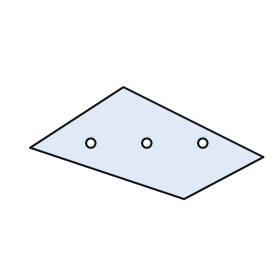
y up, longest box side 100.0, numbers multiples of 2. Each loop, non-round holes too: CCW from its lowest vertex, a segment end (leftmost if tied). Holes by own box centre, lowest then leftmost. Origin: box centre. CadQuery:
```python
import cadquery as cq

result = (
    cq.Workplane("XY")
    .moveTo(16.0, -24.0)
    .lineTo(50.0, -6.0)
    .lineTo(-10.0, 24.0)
    .lineTo(-50.0, -2.0)
    .close()
    .moveTo(-24.0, 0.0)
    .circle(2.0)
    .moveTo(0.0, 0.0)
    .circle(2.0)
    .moveTo(24.0, 0.0)
    .circle(2.0)
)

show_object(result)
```